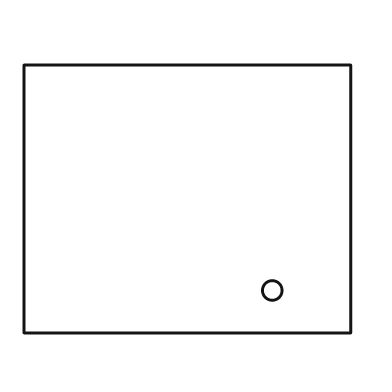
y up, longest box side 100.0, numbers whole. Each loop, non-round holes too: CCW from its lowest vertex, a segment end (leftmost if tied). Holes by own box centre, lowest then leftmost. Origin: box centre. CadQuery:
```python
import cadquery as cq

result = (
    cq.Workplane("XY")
    .moveTo(-50.0, -41.0)
    .lineTo(50.0, -41.0)
    .lineTo(50.0, 41.0)
    .lineTo(-50.0, 41.0)
    .close()
    .moveTo(26.0, -28.0)
    .circle(3.0)
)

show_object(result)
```